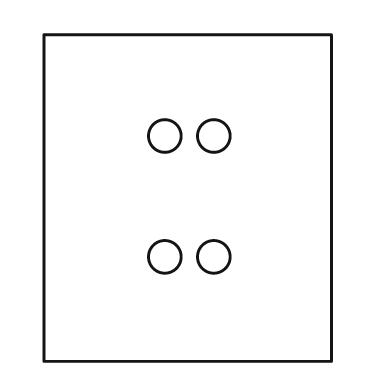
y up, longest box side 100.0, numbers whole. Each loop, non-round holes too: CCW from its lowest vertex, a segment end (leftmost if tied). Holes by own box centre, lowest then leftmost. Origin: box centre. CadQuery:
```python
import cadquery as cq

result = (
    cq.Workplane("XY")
    .moveTo(-44.0, -50.0)
    .lineTo(44.0, -50.0)
    .lineTo(44.0, 50.0)
    .lineTo(-44.0, 50.0)
    .close()
    .moveTo(-7.0, -18.0)
    .circle(5.0)
    .moveTo(8.0, -18.0)
    .circle(5.0)
    .moveTo(-7.0, 19.0)
    .circle(5.0)
    .moveTo(8.0, 19.0)
    .circle(5.0)
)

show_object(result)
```